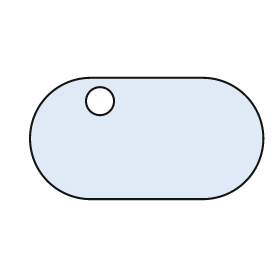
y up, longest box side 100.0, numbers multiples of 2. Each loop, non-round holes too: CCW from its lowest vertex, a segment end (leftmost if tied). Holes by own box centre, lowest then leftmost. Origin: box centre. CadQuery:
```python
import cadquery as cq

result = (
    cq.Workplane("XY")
    .moveTo(-24.0, -26.0)
    .lineTo(24.0, -26.0)
    .threePointArc((50.0, 0.0), (24.0, 26.0))
    .lineTo(-24.0, 26.0)
    .threePointArc((-50.0, 0.0), (-24.0, -26.0))
    .close()
    .moveTo(-20.0, 16.0)
    .circle(6.0)
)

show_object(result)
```